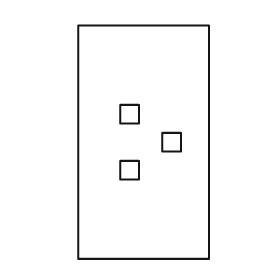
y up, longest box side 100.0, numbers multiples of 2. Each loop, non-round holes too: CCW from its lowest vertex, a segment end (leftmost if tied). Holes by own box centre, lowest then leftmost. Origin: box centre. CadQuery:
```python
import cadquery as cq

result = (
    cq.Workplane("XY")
    .moveTo(-28.0, -50.0)
    .lineTo(28.0, -50.0)
    .lineTo(28.0, 50.0)
    .lineTo(-28.0, 50.0)
    .close()
    .moveTo(-10.0, -16.0)
    .lineTo(-2.0, -16.0)
    .lineTo(-2.0, -8.0)
    .lineTo(-10.0, -8.0)
    .close()
    .moveTo(8.0, -4.0)
    .lineTo(16.0, -4.0)
    .lineTo(16.0, 4.0)
    .lineTo(8.0, 4.0)
    .close()
    .moveTo(-10.0, 8.0)
    .lineTo(-2.0, 8.0)
    .lineTo(-2.0, 16.0)
    .lineTo(-10.0, 16.0)
    .close()
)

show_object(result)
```